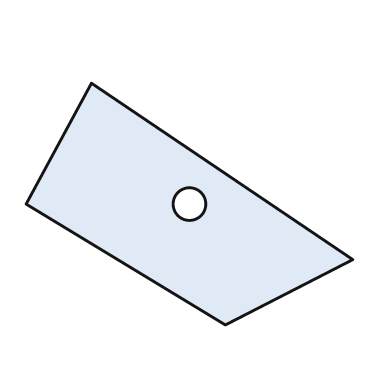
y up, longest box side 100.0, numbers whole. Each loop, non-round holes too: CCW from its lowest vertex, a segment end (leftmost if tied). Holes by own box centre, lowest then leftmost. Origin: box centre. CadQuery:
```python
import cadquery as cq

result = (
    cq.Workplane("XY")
    .moveTo(11.0, -37.0)
    .lineTo(50.0, -17.0)
    .lineTo(-30.0, 37.0)
    .lineTo(-50.0, 0.0)
    .close()
    .moveTo(0.0, 0.0)
    .circle(5.0)
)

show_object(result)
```